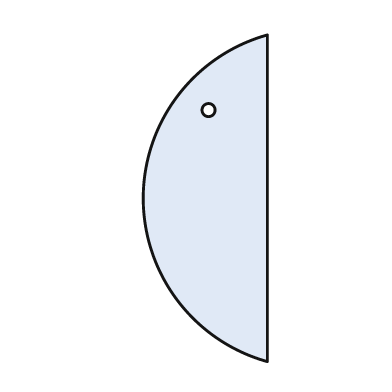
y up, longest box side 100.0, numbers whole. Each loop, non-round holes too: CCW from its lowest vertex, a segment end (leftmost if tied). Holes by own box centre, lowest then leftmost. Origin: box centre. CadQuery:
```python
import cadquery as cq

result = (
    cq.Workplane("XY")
    .moveTo(19.0, -50.0)
    .lineTo(19.0, 50.0)
    .threePointArc((-19.0, 0.0), (19.0, -50.0))
    .close()
    .moveTo(1.0, 27.0)
    .circle(2.0)
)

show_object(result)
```